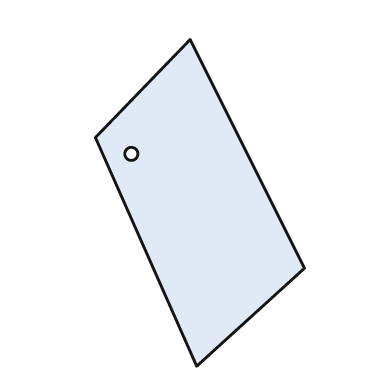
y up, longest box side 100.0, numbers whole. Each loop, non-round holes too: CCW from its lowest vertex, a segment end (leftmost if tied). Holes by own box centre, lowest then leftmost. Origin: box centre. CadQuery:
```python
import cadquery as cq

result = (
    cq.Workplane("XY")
    .moveTo(-1.0, -50.0)
    .lineTo(32.0, -20.0)
    .lineTo(-3.0, 50.0)
    .lineTo(-32.0, 20.0)
    .close()
    .moveTo(-21.0, 15.0)
    .circle(2.0)
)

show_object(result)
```